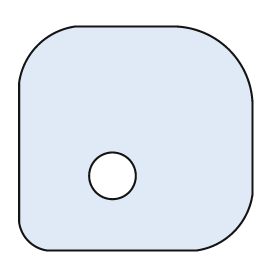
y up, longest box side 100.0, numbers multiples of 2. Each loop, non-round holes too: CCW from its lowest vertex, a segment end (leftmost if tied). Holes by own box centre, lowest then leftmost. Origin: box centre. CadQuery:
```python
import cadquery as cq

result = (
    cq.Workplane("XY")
    .moveTo(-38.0, -48.0)
    .lineTo(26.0, -48.0)
    .threePointArc((42.0, -40.0), (50.0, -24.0))
    .lineTo(50.0, 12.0)
    .threePointArc((40.0, 38.0), (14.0, 48.0))
    .lineTo(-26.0, 48.0)
    .threePointArc((-42.0, 40.0), (-50.0, 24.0))
    .lineTo(-50.0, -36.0)
    .threePointArc((-46.0, -44.0), (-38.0, -48.0))
    .close()
    .moveTo(-10.0, -16.0)
    .circle(10.0)
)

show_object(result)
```